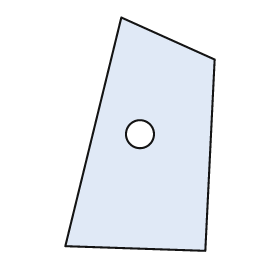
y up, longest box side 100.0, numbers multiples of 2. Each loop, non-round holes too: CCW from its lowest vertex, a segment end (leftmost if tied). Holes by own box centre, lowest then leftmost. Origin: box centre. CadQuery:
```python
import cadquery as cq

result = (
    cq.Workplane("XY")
    .moveTo(28.0, -50.0)
    .lineTo(32.0, 32.0)
    .lineTo(-8.0, 50.0)
    .lineTo(-32.0, -48.0)
    .close()
    .moveTo(0.0, 0.0)
    .circle(6.0)
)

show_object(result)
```